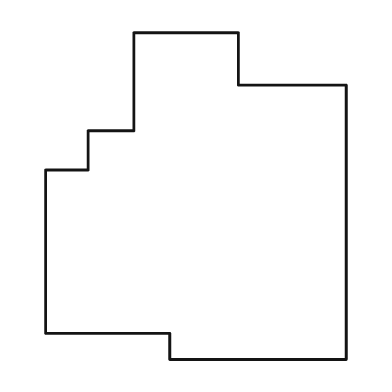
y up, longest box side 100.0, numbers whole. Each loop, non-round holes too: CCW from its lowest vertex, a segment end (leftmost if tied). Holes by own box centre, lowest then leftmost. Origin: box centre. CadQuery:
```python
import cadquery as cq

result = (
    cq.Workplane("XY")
    .moveTo(-8.0, -50.0)
    .lineTo(46.0, -50.0)
    .lineTo(46.0, 34.0)
    .lineTo(13.0, 34.0)
    .lineTo(13.0, 50.0)
    .lineTo(-19.0, 50.0)
    .lineTo(-19.0, 20.0)
    .lineTo(-33.0, 20.0)
    .lineTo(-33.0, 8.0)
    .lineTo(-46.0, 8.0)
    .lineTo(-46.0, -42.0)
    .lineTo(-8.0, -42.0)
    .close()
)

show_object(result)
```